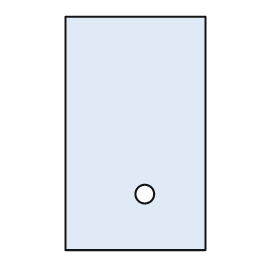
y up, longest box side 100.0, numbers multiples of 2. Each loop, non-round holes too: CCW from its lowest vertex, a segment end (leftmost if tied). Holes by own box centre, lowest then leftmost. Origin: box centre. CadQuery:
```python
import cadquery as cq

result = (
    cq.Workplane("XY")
    .moveTo(-30.0, -50.0)
    .lineTo(30.0, -50.0)
    .lineTo(30.0, 50.0)
    .lineTo(-30.0, 50.0)
    .close()
    .moveTo(4.0, -26.0)
    .circle(4.0)
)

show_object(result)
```